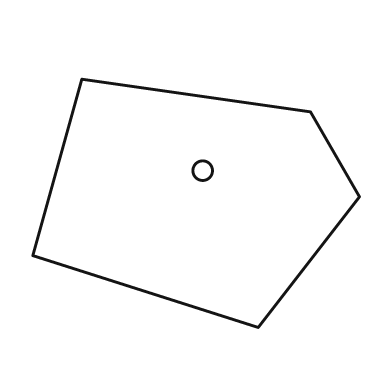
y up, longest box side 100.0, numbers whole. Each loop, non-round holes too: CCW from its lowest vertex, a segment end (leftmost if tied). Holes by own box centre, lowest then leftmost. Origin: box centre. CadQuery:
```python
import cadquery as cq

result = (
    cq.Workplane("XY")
    .moveTo(19.0, -38.0)
    .lineTo(50.0, 2.0)
    .lineTo(35.0, 28.0)
    .lineTo(-35.0, 38.0)
    .lineTo(-50.0, -16.0)
    .close()
    .moveTo(2.0, 10.0)
    .circle(3.0)
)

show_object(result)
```